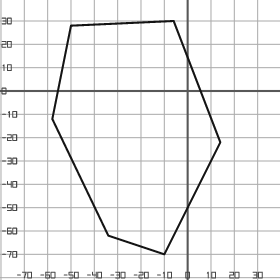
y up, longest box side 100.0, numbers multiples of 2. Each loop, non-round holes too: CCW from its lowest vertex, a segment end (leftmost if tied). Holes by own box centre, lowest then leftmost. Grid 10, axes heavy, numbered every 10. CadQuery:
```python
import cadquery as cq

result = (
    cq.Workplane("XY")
    .moveTo(-10.0, -70.0)
    .lineTo(14.0, -22.0)
    .lineTo(-6.0, 30.0)
    .lineTo(-50.0, 28.0)
    .lineTo(-58.0, -12.0)
    .lineTo(-34.0, -62.0)
    .close()
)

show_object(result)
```